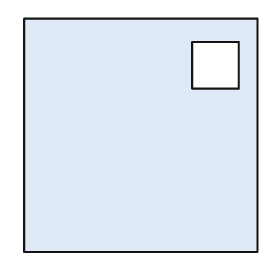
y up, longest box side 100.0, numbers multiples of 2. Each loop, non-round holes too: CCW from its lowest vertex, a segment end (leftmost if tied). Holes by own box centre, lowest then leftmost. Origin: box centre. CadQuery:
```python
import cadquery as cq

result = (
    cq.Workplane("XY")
    .moveTo(-50.0, -50.0)
    .lineTo(50.0, -50.0)
    .lineTo(50.0, 50.0)
    .lineTo(-50.0, 50.0)
    .close()
    .moveTo(22.0, 20.0)
    .lineTo(42.0, 20.0)
    .lineTo(42.0, 40.0)
    .lineTo(22.0, 40.0)
    .close()
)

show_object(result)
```